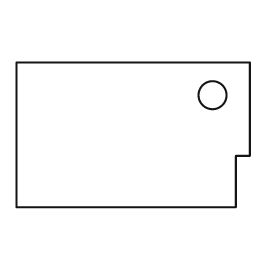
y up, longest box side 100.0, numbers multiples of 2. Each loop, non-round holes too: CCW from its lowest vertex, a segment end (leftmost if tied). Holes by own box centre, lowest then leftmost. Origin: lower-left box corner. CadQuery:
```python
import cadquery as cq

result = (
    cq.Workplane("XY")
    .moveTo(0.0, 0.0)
    .lineTo(94.0, 0.0)
    .lineTo(94.0, 22.0)
    .lineTo(100.0, 22.0)
    .lineTo(100.0, 62.0)
    .lineTo(0.0, 62.0)
    .close()
    .moveTo(84.0, 48.0)
    .circle(6.0)
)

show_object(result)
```